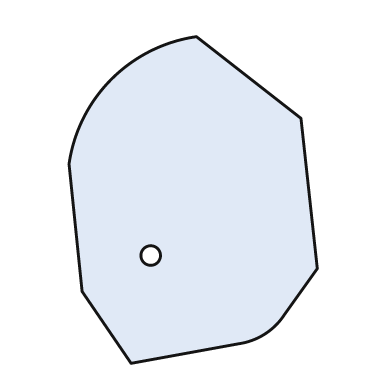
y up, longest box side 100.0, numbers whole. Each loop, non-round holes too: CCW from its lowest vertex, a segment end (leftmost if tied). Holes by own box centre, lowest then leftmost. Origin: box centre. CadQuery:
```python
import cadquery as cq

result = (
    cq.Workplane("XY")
    .moveTo(-19.0, -50.0)
    .lineTo(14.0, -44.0)
    .threePointArc((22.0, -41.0), (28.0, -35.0))
    .lineTo(38.0, -21.0)
    .lineTo(33.0, 25.0)
    .lineTo(1.0, 50.0)
    .threePointArc((-25.0, 37.0), (-38.0, 11.0))
    .lineTo(-34.0, -28.0)
    .close()
    .moveTo(-13.0, -17.0)
    .circle(3.0)
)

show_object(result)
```